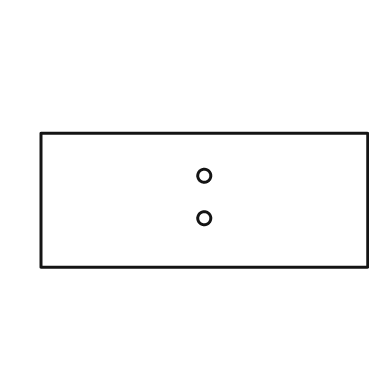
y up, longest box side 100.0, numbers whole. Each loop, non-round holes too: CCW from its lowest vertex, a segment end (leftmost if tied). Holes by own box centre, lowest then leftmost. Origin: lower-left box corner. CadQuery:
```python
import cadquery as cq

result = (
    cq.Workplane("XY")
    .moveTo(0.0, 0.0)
    .lineTo(100.0, 0.0)
    .lineTo(100.0, 41.0)
    .lineTo(0.0, 41.0)
    .close()
    .moveTo(50.0, 15.0)
    .circle(2.0)
    .moveTo(50.0, 28.0)
    .circle(2.0)
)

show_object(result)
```